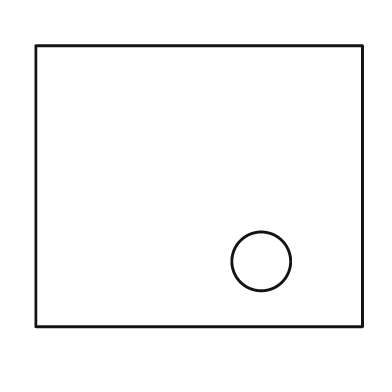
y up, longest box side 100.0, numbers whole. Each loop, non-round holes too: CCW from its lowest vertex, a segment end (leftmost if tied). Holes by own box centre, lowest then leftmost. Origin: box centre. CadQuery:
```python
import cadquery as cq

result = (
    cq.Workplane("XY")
    .moveTo(-50.0, -43.0)
    .lineTo(50.0, -43.0)
    .lineTo(50.0, 43.0)
    .lineTo(-50.0, 43.0)
    .close()
    .moveTo(19.0, -23.0)
    .circle(9.0)
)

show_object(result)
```